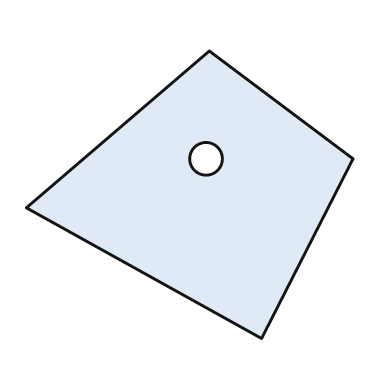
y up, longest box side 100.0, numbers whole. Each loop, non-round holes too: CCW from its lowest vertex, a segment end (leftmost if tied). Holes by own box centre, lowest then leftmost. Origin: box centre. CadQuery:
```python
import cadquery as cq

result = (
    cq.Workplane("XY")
    .moveTo(22.0, -44.0)
    .lineTo(50.0, 11.0)
    .lineTo(6.0, 44.0)
    .lineTo(-50.0, -4.0)
    .close()
    .moveTo(5.0, 11.0)
    .circle(5.0)
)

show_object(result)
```